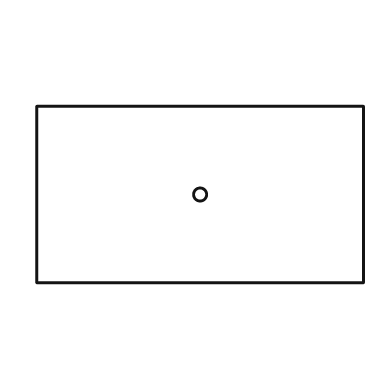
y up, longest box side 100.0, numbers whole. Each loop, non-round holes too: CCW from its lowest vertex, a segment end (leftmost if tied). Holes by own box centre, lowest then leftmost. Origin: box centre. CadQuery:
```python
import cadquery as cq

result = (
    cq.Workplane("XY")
    .moveTo(-50.0, -27.0)
    .lineTo(50.0, -27.0)
    .lineTo(50.0, 27.0)
    .lineTo(-50.0, 27.0)
    .close()
    .moveTo(0.0, 0.0)
    .circle(2.0)
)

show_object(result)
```